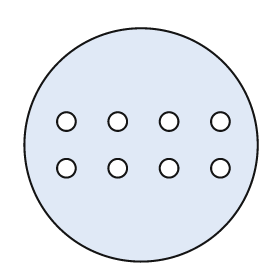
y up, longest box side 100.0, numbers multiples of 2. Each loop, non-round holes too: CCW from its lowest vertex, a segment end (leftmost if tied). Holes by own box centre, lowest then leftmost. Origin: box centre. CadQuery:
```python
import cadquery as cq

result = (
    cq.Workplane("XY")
    .moveTo(0.0, 0.0)
    .circle(50.0)
    .moveTo(-32.0, -10.0)
    .circle(4.0)
    .moveTo(-10.0, -10.0)
    .circle(4.0)
    .moveTo(12.0, -10.0)
    .circle(4.0)
    .moveTo(34.0, -10.0)
    .circle(4.0)
    .moveTo(-32.0, 10.0)
    .circle(4.0)
    .moveTo(-10.0, 10.0)
    .circle(4.0)
    .moveTo(12.0, 10.0)
    .circle(4.0)
    .moveTo(34.0, 10.0)
    .circle(4.0)
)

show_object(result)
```